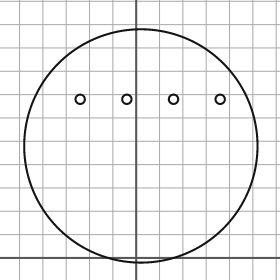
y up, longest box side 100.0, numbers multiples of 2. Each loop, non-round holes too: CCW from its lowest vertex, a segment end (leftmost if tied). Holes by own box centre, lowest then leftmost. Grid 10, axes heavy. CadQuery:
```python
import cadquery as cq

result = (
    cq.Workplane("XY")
    .moveTo(2.0, 48.0)
    .circle(50.0)
    .moveTo(-24.0, 68.0)
    .circle(2.0)
    .moveTo(-4.0, 68.0)
    .circle(2.0)
    .moveTo(16.0, 68.0)
    .circle(2.0)
    .moveTo(36.0, 68.0)
    .circle(2.0)
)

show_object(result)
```